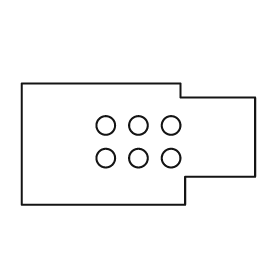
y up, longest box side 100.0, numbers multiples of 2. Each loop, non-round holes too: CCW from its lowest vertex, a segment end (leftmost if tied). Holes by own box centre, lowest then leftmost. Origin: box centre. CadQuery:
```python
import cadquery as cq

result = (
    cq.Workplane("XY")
    .moveTo(-50.0, -26.0)
    .lineTo(20.0, -26.0)
    .lineTo(20.0, -14.0)
    .lineTo(50.0, -14.0)
    .lineTo(50.0, 20.0)
    .lineTo(18.0, 20.0)
    .lineTo(18.0, 26.0)
    .lineTo(-50.0, 26.0)
    .close()
    .moveTo(-14.0, -6.0)
    .circle(4.0)
    .moveTo(0.0, -6.0)
    .circle(4.0)
    .moveTo(14.0, -6.0)
    .circle(4.0)
    .moveTo(-14.0, 8.0)
    .circle(4.0)
    .moveTo(0.0, 8.0)
    .circle(4.0)
    .moveTo(14.0, 8.0)
    .circle(4.0)
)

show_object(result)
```